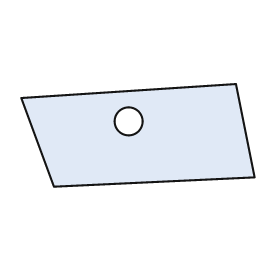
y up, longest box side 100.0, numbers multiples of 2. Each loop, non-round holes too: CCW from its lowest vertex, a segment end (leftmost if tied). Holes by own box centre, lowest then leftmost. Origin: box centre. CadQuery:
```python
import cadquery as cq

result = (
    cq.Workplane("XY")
    .moveTo(-36.0, -22.0)
    .lineTo(50.0, -18.0)
    .lineTo(42.0, 22.0)
    .lineTo(-50.0, 16.0)
    .close()
    .moveTo(-4.0, 6.0)
    .circle(6.0)
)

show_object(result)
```